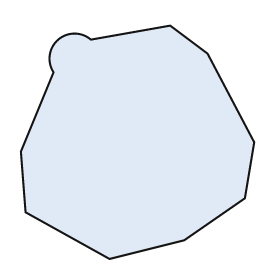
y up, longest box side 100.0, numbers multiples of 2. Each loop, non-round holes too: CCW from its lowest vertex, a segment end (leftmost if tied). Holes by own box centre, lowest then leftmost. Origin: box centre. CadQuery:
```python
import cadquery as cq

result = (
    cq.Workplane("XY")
    .moveTo(-12.0, -50.0)
    .lineTo(20.0, -42.0)
    .lineTo(46.0, -24.0)
    .lineTo(50.0, 0.0)
    .lineTo(30.0, 38.0)
    .lineTo(14.0, 50.0)
    .lineTo(-20.0, 44.0)
    .threePointArc((-34.0, 44.0), (-36.0, 30.0))
    .lineTo(-50.0, -4.0)
    .lineTo(-48.0, -30.0)
    .close()
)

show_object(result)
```